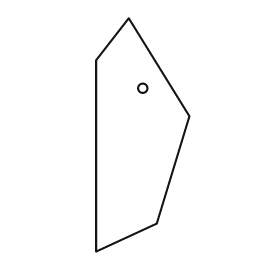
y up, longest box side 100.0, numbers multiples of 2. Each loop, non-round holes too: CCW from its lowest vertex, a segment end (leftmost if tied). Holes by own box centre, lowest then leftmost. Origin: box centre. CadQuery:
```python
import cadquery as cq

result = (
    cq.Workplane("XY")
    .moveTo(-20.0, -50.0)
    .lineTo(6.0, -38.0)
    .lineTo(20.0, 8.0)
    .lineTo(-6.0, 50.0)
    .lineTo(-20.0, 32.0)
    .close()
    .moveTo(0.0, 20.0)
    .circle(2.0)
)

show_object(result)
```